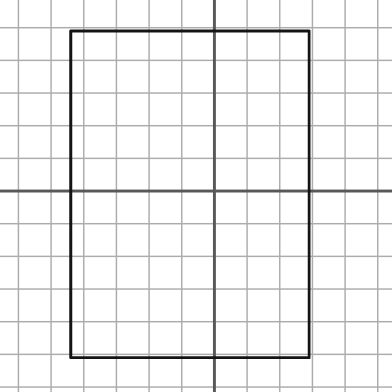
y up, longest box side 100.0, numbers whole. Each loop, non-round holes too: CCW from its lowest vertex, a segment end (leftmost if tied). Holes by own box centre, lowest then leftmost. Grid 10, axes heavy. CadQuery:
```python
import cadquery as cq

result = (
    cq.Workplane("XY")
    .moveTo(-44.0, -51.0)
    .lineTo(29.0, -51.0)
    .lineTo(29.0, 49.0)
    .lineTo(-44.0, 49.0)
    .close()
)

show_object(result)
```